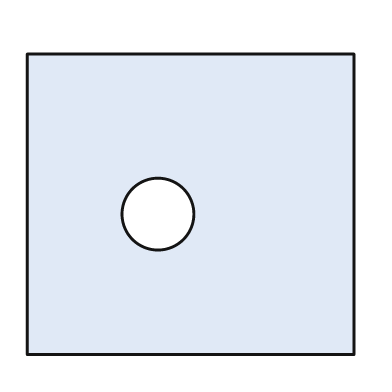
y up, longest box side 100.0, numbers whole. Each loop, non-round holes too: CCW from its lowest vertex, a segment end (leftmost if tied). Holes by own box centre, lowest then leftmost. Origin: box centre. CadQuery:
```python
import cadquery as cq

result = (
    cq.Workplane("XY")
    .moveTo(-50.0, -46.0)
    .lineTo(50.0, -46.0)
    .lineTo(50.0, 46.0)
    .lineTo(-50.0, 46.0)
    .close()
    .moveTo(-10.0, -3.0)
    .circle(11.0)
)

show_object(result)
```